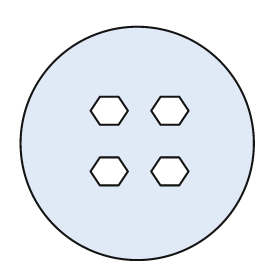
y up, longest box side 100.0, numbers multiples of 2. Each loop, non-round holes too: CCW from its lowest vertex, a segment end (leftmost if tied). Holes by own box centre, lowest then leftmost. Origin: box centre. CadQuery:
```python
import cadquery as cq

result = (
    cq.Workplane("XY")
    .moveTo(0.0, 0.0)
    .circle(50.0)
    .moveTo(-16.0, -18.0)
    .lineTo(-8.0, -18.0)
    .lineTo(-4.0, -12.0)
    .lineTo(-8.0, -6.0)
    .lineTo(-16.0, -6.0)
    .lineTo(-20.0, -12.0)
    .close()
    .moveTo(10.0, -18.0)
    .lineTo(18.0, -18.0)
    .lineTo(22.0, -12.0)
    .lineTo(18.0, -6.0)
    .lineTo(10.0, -6.0)
    .lineTo(6.0, -12.0)
    .close()
    .moveTo(-16.0, 8.0)
    .lineTo(-8.0, 8.0)
    .lineTo(-4.0, 14.0)
    .lineTo(-8.0, 20.0)
    .lineTo(-16.0, 20.0)
    .lineTo(-20.0, 14.0)
    .close()
    .moveTo(10.0, 8.0)
    .lineTo(18.0, 8.0)
    .lineTo(22.0, 14.0)
    .lineTo(18.0, 20.0)
    .lineTo(10.0, 20.0)
    .lineTo(6.0, 14.0)
    .close()
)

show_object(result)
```